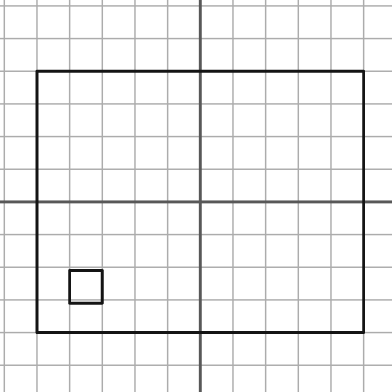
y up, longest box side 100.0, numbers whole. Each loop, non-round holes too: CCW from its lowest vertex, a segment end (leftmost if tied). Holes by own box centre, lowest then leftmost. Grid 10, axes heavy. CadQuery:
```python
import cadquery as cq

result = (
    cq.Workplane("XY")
    .moveTo(-50.0, -40.0)
    .lineTo(50.0, -40.0)
    .lineTo(50.0, 40.0)
    .lineTo(-50.0, 40.0)
    .close()
    .moveTo(-40.0, -31.0)
    .lineTo(-30.0, -31.0)
    .lineTo(-30.0, -21.0)
    .lineTo(-40.0, -21.0)
    .close()
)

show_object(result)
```